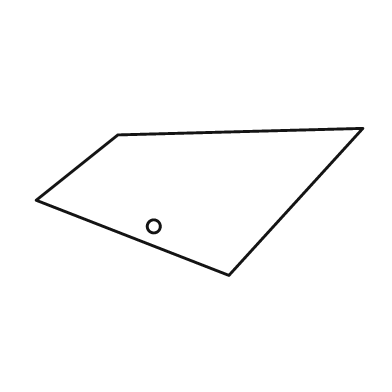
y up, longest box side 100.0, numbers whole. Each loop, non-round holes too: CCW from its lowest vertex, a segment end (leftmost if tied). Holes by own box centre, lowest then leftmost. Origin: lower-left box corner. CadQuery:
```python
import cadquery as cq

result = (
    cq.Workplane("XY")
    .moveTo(59.0, 0.0)
    .lineTo(100.0, 45.0)
    .lineTo(25.0, 43.0)
    .lineTo(0.0, 23.0)
    .close()
    .moveTo(36.0, 15.0)
    .circle(2.0)
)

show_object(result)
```